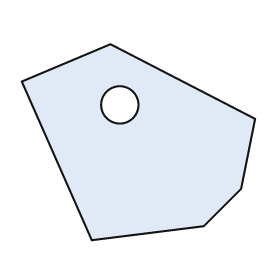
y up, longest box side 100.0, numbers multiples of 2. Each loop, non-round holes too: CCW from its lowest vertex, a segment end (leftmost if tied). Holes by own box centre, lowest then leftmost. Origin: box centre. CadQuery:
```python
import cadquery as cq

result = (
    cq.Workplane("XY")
    .moveTo(-20.0, -42.0)
    .lineTo(28.0, -36.0)
    .lineTo(44.0, -20.0)
    .lineTo(50.0, 10.0)
    .lineTo(-12.0, 42.0)
    .lineTo(-50.0, 26.0)
    .close()
    .moveTo(-8.0, 16.0)
    .circle(8.0)
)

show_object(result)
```